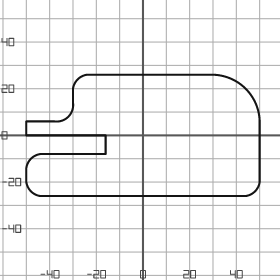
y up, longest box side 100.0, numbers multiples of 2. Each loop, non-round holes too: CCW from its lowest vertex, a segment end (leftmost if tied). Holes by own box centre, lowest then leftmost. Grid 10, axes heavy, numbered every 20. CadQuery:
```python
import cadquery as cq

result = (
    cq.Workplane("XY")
    .moveTo(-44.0, -26.0)
    .lineTo(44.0, -26.0)
    .threePointArc((48.0, -24.0), (50.0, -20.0))
    .lineTo(50.0, 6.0)
    .threePointArc((44.0, 20.0), (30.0, 26.0))
    .lineTo(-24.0, 26.0)
    .threePointArc((-28.0, 24.0), (-30.0, 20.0))
    .lineTo(-30.0, 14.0)
    .threePointArc((-32.0, 8.0), (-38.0, 6.0))
    .lineTo(-50.0, 6.0)
    .lineTo(-50.0, 0.0)
    .lineTo(-16.0, 0.0)
    .lineTo(-16.0, -8.0)
    .lineTo(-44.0, -8.0)
    .threePointArc((-48.0, -10.0), (-50.0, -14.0))
    .lineTo(-50.0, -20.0)
    .threePointArc((-48.0, -24.0), (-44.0, -26.0))
    .close()
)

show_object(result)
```